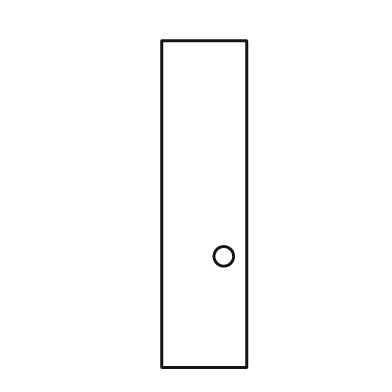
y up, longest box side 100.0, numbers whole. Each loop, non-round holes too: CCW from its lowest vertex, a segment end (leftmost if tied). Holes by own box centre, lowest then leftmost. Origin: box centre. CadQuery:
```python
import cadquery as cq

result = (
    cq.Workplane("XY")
    .moveTo(-13.0, -50.0)
    .lineTo(13.0, -50.0)
    .lineTo(13.0, 50.0)
    .lineTo(-13.0, 50.0)
    .close()
    .moveTo(6.0, -16.0)
    .circle(3.0)
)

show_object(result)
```